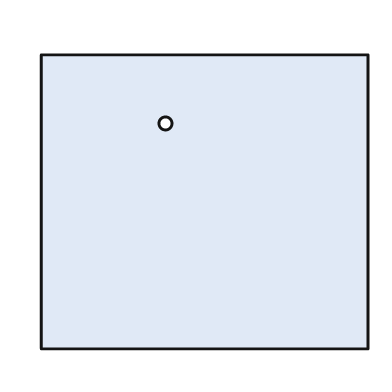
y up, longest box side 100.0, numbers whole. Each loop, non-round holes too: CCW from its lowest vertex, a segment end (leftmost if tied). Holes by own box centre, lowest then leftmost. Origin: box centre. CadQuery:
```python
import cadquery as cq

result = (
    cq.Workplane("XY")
    .moveTo(-50.0, -45.0)
    .lineTo(50.0, -45.0)
    .lineTo(50.0, 45.0)
    .lineTo(-50.0, 45.0)
    .close()
    .moveTo(-12.0, 24.0)
    .circle(2.0)
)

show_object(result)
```